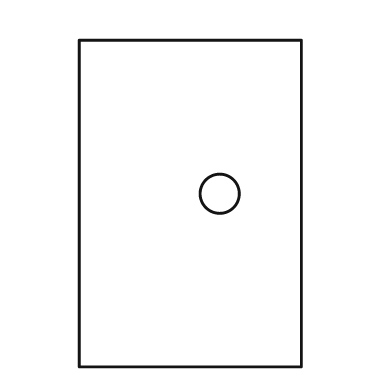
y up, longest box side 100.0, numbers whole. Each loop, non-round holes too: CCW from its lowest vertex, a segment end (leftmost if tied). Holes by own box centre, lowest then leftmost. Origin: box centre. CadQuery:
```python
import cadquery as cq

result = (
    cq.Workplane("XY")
    .moveTo(-34.0, -50.0)
    .lineTo(34.0, -50.0)
    .lineTo(34.0, 50.0)
    .lineTo(-34.0, 50.0)
    .close()
    .moveTo(9.0, 3.0)
    .circle(6.0)
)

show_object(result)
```